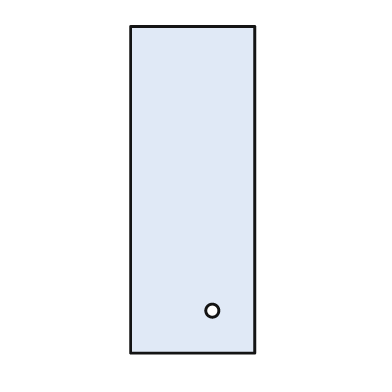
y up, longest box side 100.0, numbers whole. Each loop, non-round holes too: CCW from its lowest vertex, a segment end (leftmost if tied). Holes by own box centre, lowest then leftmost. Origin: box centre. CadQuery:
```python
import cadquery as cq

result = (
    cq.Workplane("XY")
    .moveTo(-19.0, -50.0)
    .lineTo(19.0, -50.0)
    .lineTo(19.0, 50.0)
    .lineTo(-19.0, 50.0)
    .close()
    .moveTo(6.0, -37.0)
    .circle(2.0)
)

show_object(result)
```